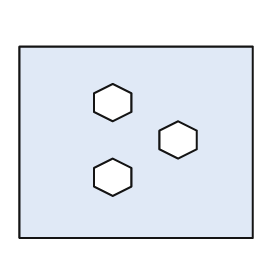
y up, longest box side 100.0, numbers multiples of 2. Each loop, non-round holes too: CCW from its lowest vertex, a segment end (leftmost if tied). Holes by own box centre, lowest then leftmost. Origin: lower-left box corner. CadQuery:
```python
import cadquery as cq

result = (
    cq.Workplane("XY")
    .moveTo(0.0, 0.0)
    .lineTo(100.0, 0.0)
    .lineTo(100.0, 82.0)
    .lineTo(0.0, 82.0)
    .close()
    .moveTo(40.0, 18.0)
    .lineTo(48.0, 22.0)
    .lineTo(48.0, 30.0)
    .lineTo(40.0, 34.0)
    .lineTo(32.0, 30.0)
    .lineTo(32.0, 22.0)
    .close()
    .moveTo(68.0, 34.0)
    .lineTo(76.0, 38.0)
    .lineTo(76.0, 46.0)
    .lineTo(68.0, 50.0)
    .lineTo(60.0, 46.0)
    .lineTo(60.0, 38.0)
    .close()
    .moveTo(40.0, 50.0)
    .lineTo(48.0, 54.0)
    .lineTo(48.0, 62.0)
    .lineTo(40.0, 66.0)
    .lineTo(32.0, 62.0)
    .lineTo(32.0, 54.0)
    .close()
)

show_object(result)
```